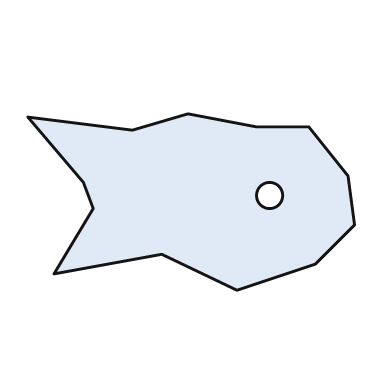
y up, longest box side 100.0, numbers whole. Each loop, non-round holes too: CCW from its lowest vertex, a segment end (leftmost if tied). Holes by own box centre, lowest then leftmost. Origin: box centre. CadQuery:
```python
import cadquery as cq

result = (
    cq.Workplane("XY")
    .moveTo(14.0, -27.0)
    .lineTo(38.0, -19.0)
    .lineTo(50.0, -7.0)
    .lineTo(48.0, 8.0)
    .lineTo(36.0, 23.0)
    .lineTo(20.0, 23.0)
    .lineTo(-1.0, 27.0)
    .lineTo(-18.0, 22.0)
    .lineTo(-50.0, 26.0)
    .lineTo(-33.0, 6.0)
    .lineTo(-30.0, -2.0)
    .lineTo(-42.0, -22.0)
    .lineTo(-9.0, -16.0)
    .close()
    .moveTo(24.0, 2.0)
    .circle(4.0)
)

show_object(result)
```